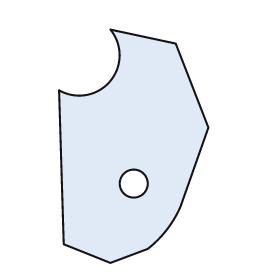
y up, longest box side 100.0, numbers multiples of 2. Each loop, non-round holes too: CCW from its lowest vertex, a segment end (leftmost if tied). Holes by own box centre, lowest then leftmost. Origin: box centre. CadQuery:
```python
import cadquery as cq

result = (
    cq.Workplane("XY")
    .moveTo(-10.0, -50.0)
    .lineTo(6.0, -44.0)
    .threePointArc((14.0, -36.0), (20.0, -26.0))
    .lineTo(32.0, 8.0)
    .lineTo(18.0, 44.0)
    .lineTo(-10.0, 50.0)
    .threePointArc((-10.0, 28.0), (-32.0, 24.0))
    .lineTo(-30.0, -42.0)
    .close()
    .moveTo(0.0, -16.0)
    .circle(6.0)
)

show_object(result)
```